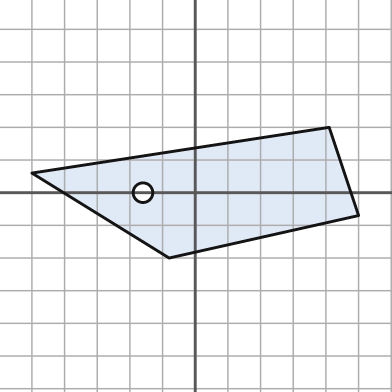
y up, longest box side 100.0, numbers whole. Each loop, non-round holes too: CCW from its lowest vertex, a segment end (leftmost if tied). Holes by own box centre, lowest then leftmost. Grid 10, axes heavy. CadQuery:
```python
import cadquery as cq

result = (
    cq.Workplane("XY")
    .moveTo(-8.0, -20.0)
    .lineTo(50.0, -7.0)
    .lineTo(41.0, 20.0)
    .lineTo(-50.0, 6.0)
    .close()
    .moveTo(-16.0, 0.0)
    .circle(3.0)
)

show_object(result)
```